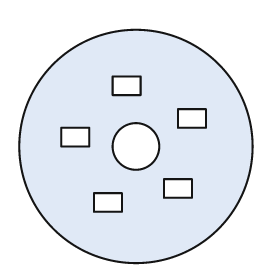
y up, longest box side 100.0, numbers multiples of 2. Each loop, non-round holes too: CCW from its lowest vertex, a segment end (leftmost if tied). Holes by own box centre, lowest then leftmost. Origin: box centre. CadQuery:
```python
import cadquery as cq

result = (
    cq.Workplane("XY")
    .moveTo(0.0, 0.0)
    .circle(50.0)
    .moveTo(-18.0, -28.0)
    .lineTo(-6.0, -28.0)
    .lineTo(-6.0, -20.0)
    .lineTo(-18.0, -20.0)
    .close()
    .moveTo(12.0, -22.0)
    .lineTo(24.0, -22.0)
    .lineTo(24.0, -14.0)
    .lineTo(12.0, -14.0)
    .close()
    .moveTo(0.0, 0.0)
    .circle(10.0)
    .moveTo(-32.0, 0.0)
    .lineTo(-20.0, 0.0)
    .lineTo(-20.0, 8.0)
    .lineTo(-32.0, 8.0)
    .close()
    .moveTo(18.0, 8.0)
    .lineTo(30.0, 8.0)
    .lineTo(30.0, 16.0)
    .lineTo(18.0, 16.0)
    .close()
    .moveTo(-10.0, 22.0)
    .lineTo(2.0, 22.0)
    .lineTo(2.0, 30.0)
    .lineTo(-10.0, 30.0)
    .close()
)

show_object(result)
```